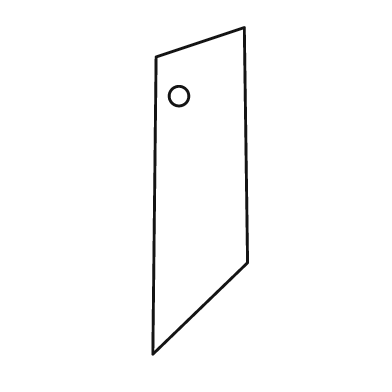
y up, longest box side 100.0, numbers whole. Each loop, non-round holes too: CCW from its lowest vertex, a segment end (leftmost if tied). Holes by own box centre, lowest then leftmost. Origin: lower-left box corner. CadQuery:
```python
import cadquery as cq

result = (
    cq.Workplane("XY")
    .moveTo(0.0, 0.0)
    .lineTo(29.0, 28.0)
    .lineTo(28.0, 100.0)
    .lineTo(1.0, 91.0)
    .close()
    .moveTo(8.0, 79.0)
    .circle(3.0)
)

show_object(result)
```